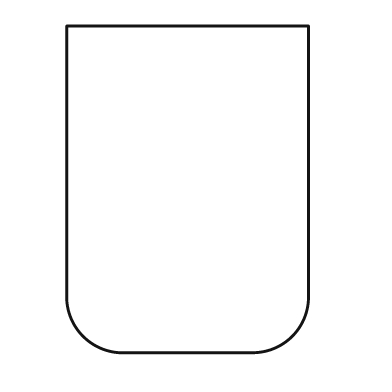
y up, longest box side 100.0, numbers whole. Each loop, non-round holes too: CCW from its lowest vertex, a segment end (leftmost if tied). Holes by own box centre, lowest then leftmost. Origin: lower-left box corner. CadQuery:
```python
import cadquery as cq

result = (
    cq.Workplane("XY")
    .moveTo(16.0, 0.0)
    .lineTo(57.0, 0.0)
    .threePointArc((69.0, 5.0), (74.0, 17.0))
    .lineTo(74.0, 100.0)
    .lineTo(0.0, 100.0)
    .lineTo(0.0, 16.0)
    .threePointArc((5.0, 5.0), (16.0, 0.0))
    .close()
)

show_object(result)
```